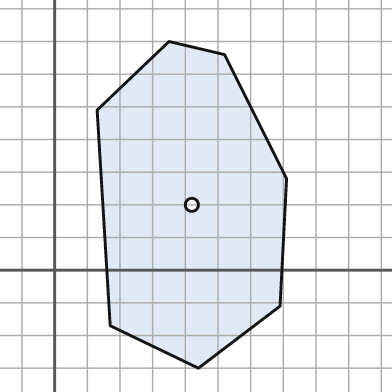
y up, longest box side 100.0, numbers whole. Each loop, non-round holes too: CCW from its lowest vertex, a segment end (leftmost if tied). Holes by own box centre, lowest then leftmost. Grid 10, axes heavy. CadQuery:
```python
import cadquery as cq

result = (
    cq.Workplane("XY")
    .moveTo(44.0, -30.0)
    .lineTo(69.0, -11.0)
    .lineTo(71.0, 28.0)
    .lineTo(52.0, 66.0)
    .lineTo(35.0, 70.0)
    .lineTo(13.0, 49.0)
    .lineTo(17.0, -17.0)
    .close()
    .moveTo(42.0, 20.0)
    .circle(2.0)
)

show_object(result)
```